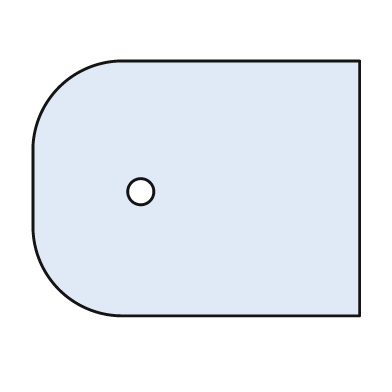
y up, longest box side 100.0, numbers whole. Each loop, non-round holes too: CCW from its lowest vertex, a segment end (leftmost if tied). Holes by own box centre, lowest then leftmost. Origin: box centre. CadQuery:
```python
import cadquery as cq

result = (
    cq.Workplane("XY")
    .moveTo(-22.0, -39.0)
    .lineTo(50.0, -39.0)
    .lineTo(50.0, 39.0)
    .lineTo(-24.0, 39.0)
    .threePointArc((-42.0, 31.0), (-50.0, 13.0))
    .lineTo(-50.0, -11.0)
    .threePointArc((-42.0, -31.0), (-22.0, -39.0))
    .close()
    .moveTo(-17.0, -1.0)
    .circle(4.0)
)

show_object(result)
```